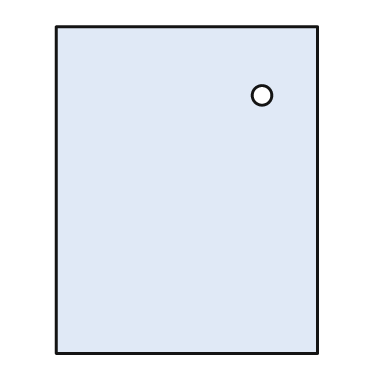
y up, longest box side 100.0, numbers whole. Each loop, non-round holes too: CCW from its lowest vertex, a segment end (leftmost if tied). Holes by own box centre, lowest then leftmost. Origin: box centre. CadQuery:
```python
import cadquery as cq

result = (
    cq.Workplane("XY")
    .moveTo(-40.0, -50.0)
    .lineTo(40.0, -50.0)
    .lineTo(40.0, 50.0)
    .lineTo(-40.0, 50.0)
    .close()
    .moveTo(23.0, 29.0)
    .circle(3.0)
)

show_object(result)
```